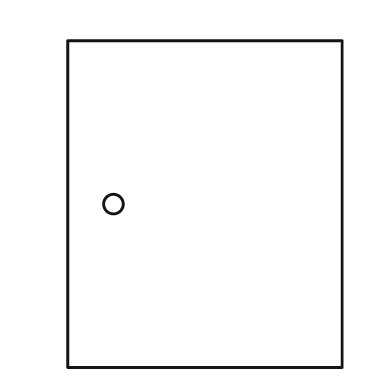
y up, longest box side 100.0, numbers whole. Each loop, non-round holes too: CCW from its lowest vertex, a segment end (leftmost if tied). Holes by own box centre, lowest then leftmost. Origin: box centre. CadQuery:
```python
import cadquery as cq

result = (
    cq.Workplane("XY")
    .moveTo(-42.0, -50.0)
    .lineTo(42.0, -50.0)
    .lineTo(42.0, 50.0)
    .lineTo(-42.0, 50.0)
    .close()
    .moveTo(-28.0, 0.0)
    .circle(3.0)
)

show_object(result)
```